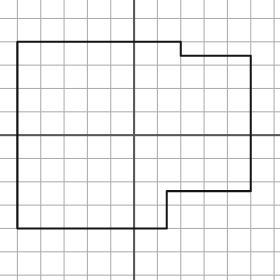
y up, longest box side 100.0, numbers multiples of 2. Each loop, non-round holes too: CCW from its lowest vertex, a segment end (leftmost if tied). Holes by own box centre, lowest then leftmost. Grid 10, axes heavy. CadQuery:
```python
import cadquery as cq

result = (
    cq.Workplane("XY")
    .moveTo(-50.0, -40.0)
    .lineTo(14.0, -40.0)
    .lineTo(14.0, -24.0)
    .lineTo(50.0, -24.0)
    .lineTo(50.0, 34.0)
    .lineTo(20.0, 34.0)
    .lineTo(20.0, 40.0)
    .lineTo(-50.0, 40.0)
    .close()
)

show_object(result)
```